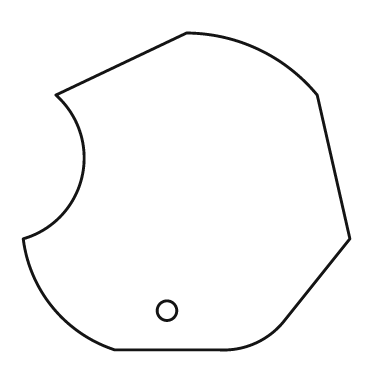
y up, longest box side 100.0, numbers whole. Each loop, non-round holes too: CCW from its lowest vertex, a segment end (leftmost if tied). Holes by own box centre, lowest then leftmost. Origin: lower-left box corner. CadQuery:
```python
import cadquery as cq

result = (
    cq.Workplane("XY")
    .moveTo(28.0, 0.0)
    .lineTo(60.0, 0.0)
    .threePointArc((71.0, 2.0), (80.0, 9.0))
    .lineTo(100.0, 34.0)
    .lineTo(90.0, 78.0)
    .threePointArc((72.0, 92.0), (50.0, 97.0))
    .lineTo(10.0, 78.0)
    .threePointArc((18.0, 53.0), (0.0, 34.0))
    .threePointArc((9.0, 13.0), (28.0, 0.0))
    .close()
    .moveTo(44.0, 12.0)
    .circle(3.0)
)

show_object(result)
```